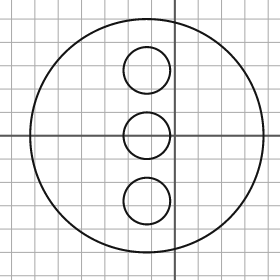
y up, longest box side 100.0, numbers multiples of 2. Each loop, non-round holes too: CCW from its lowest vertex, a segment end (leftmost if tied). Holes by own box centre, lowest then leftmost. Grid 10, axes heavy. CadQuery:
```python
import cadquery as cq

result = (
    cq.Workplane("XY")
    .moveTo(-12.0, 0.0)
    .circle(50.0)
    .moveTo(-12.0, -28.0)
    .circle(10.0)
    .moveTo(-12.0, 0.0)
    .circle(10.0)
    .moveTo(-12.0, 28.0)
    .circle(10.0)
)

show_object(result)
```